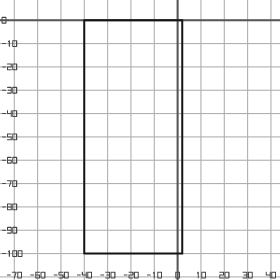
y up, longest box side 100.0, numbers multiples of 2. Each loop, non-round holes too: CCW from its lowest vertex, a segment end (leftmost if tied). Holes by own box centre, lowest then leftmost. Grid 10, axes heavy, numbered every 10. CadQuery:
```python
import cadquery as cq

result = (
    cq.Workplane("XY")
    .moveTo(-40.0, -100.0)
    .lineTo(2.0, -100.0)
    .lineTo(2.0, 0.0)
    .lineTo(-40.0, 0.0)
    .close()
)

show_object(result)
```